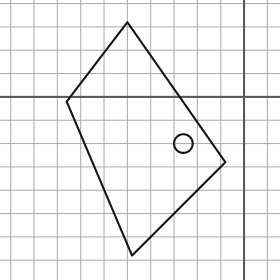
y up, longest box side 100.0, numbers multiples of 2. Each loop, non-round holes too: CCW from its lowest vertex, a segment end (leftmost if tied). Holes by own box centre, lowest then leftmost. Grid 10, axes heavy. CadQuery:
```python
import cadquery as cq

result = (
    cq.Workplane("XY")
    .moveTo(-48.0, -68.0)
    .lineTo(-8.0, -28.0)
    .lineTo(-50.0, 32.0)
    .lineTo(-76.0, -2.0)
    .close()
    .moveTo(-26.0, -20.0)
    .circle(4.0)
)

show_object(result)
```